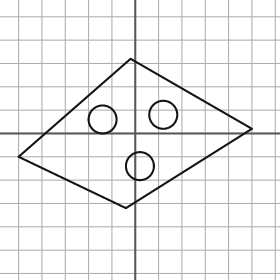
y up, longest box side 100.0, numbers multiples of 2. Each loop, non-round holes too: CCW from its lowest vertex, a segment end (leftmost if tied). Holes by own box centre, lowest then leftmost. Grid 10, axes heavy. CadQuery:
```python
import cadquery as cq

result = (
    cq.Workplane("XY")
    .moveTo(-4.0, -32.0)
    .lineTo(50.0, 2.0)
    .lineTo(-2.0, 32.0)
    .lineTo(-50.0, -10.0)
    .close()
    .moveTo(2.0, -14.0)
    .circle(6.0)
    .moveTo(-14.0, 6.0)
    .circle(6.0)
    .moveTo(12.0, 8.0)
    .circle(6.0)
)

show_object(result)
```